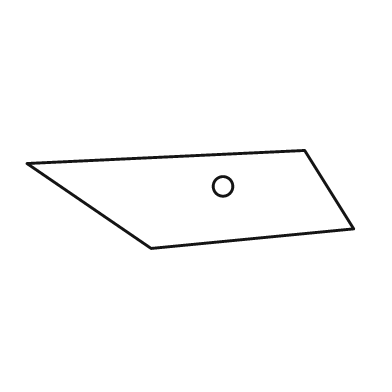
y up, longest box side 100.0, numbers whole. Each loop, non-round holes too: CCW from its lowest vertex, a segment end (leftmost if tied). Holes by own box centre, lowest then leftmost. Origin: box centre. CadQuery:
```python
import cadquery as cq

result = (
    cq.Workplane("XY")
    .moveTo(-12.0, -15.0)
    .lineTo(50.0, -9.0)
    .lineTo(35.0, 15.0)
    .lineTo(-50.0, 11.0)
    .close()
    .moveTo(10.0, 4.0)
    .circle(3.0)
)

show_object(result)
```